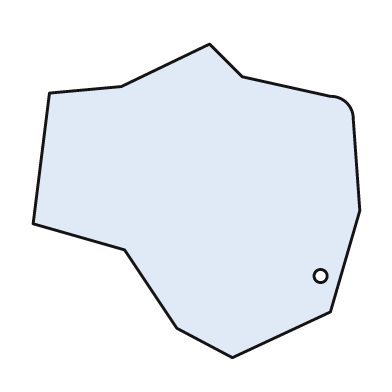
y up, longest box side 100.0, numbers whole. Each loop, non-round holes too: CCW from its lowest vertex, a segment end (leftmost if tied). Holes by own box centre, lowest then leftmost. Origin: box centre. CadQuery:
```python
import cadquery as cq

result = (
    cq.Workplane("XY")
    .moveTo(11.0, -48.0)
    .lineTo(41.0, -34.0)
    .lineTo(50.0, -3.0)
    .lineTo(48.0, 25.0)
    .threePointArc((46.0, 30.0), (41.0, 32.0))
    .lineTo(14.0, 38.0)
    .lineTo(4.0, 48.0)
    .lineTo(-23.0, 35.0)
    .lineTo(-45.0, 33.0)
    .lineTo(-50.0, -7.0)
    .lineTo(-22.0, -15.0)
    .lineTo(-6.0, -39.0)
    .close()
    .moveTo(38.0, -23.0)
    .circle(2.0)
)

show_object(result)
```